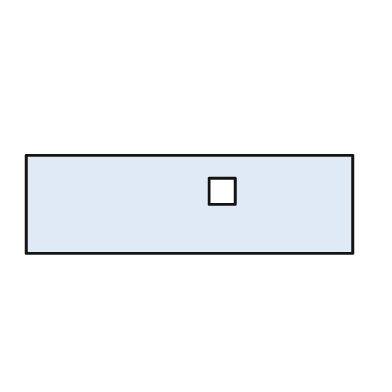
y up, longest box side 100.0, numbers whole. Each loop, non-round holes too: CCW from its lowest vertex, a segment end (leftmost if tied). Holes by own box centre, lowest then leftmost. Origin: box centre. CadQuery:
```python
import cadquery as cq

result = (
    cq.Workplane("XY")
    .moveTo(-50.0, -15.0)
    .lineTo(50.0, -15.0)
    .lineTo(50.0, 15.0)
    .lineTo(-50.0, 15.0)
    .close()
    .moveTo(6.0, 0.0)
    .lineTo(14.0, 0.0)
    .lineTo(14.0, 8.0)
    .lineTo(6.0, 8.0)
    .close()
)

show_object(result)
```